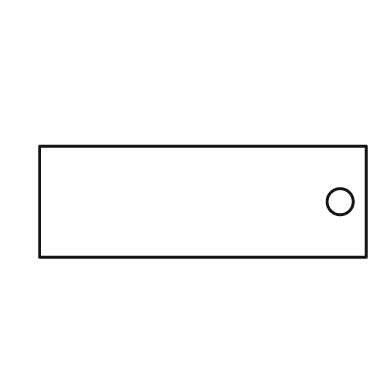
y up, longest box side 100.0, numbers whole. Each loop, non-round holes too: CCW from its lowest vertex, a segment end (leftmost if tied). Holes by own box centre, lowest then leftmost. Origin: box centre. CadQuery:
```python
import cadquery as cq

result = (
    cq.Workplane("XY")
    .moveTo(-50.0, -17.0)
    .lineTo(50.0, -17.0)
    .lineTo(50.0, 17.0)
    .lineTo(-50.0, 17.0)
    .close()
    .moveTo(42.0, 0.0)
    .circle(4.0)
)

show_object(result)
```